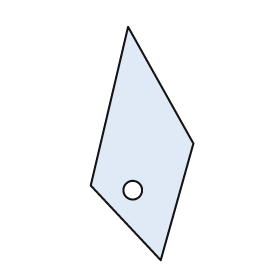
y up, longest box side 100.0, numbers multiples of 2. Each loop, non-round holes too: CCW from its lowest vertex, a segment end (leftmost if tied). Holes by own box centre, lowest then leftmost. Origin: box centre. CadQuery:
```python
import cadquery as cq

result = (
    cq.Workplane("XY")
    .moveTo(8.0, -50.0)
    .lineTo(22.0, 0.0)
    .lineTo(-6.0, 50.0)
    .lineTo(-22.0, -18.0)
    .close()
    .moveTo(-4.0, -20.0)
    .circle(4.0)
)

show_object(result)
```